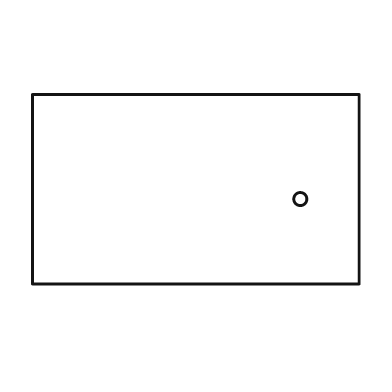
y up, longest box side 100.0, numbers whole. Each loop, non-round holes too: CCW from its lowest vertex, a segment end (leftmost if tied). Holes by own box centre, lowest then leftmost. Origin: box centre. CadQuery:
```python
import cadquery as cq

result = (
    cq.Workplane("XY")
    .moveTo(-50.0, -29.0)
    .lineTo(50.0, -29.0)
    .lineTo(50.0, 29.0)
    .lineTo(-50.0, 29.0)
    .close()
    .moveTo(32.0, -3.0)
    .circle(2.0)
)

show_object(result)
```